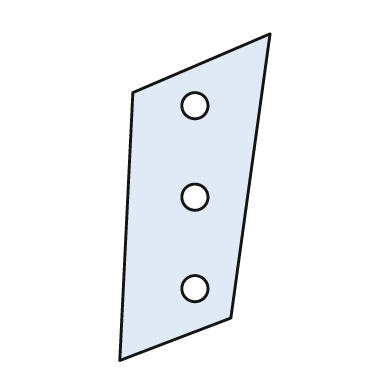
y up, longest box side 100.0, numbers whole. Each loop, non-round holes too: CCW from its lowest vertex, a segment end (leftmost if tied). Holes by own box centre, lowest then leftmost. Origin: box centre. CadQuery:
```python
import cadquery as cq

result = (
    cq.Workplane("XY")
    .moveTo(-23.0, -50.0)
    .lineTo(11.0, -37.0)
    .lineTo(23.0, 50.0)
    .lineTo(-19.0, 32.0)
    .close()
    .moveTo(0.0, -28.0)
    .circle(4.0)
    .moveTo(0.0, 0.0)
    .circle(4.0)
    .moveTo(0.0, 28.0)
    .circle(4.0)
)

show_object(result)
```